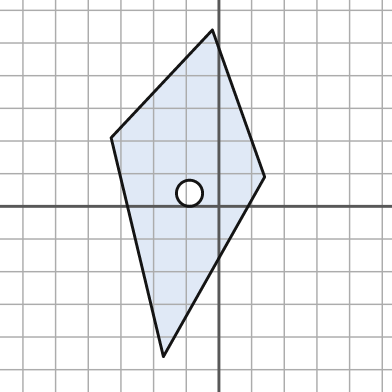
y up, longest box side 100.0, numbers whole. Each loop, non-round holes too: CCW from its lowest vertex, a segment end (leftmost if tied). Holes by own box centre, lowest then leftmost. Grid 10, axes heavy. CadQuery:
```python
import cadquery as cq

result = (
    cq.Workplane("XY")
    .moveTo(-17.0, -46.0)
    .lineTo(14.0, 9.0)
    .lineTo(-2.0, 54.0)
    .lineTo(-33.0, 21.0)
    .close()
    .moveTo(-9.0, 4.0)
    .circle(4.0)
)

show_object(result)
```